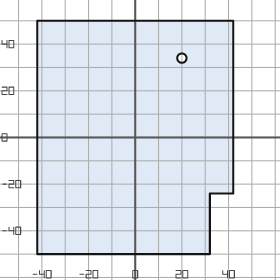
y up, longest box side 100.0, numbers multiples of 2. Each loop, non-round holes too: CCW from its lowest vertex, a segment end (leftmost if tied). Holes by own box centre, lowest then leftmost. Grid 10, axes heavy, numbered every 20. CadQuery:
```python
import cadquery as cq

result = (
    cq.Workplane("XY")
    .moveTo(-42.0, -50.0)
    .lineTo(32.0, -50.0)
    .lineTo(32.0, -24.0)
    .lineTo(42.0, -24.0)
    .lineTo(42.0, 50.0)
    .lineTo(-42.0, 50.0)
    .close()
    .moveTo(20.0, 34.0)
    .circle(2.0)
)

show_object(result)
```